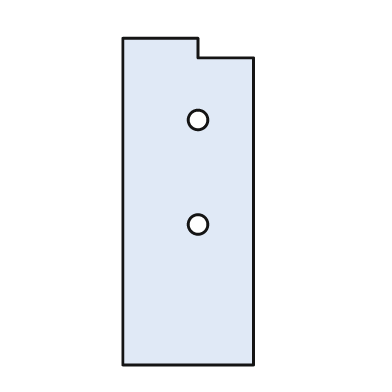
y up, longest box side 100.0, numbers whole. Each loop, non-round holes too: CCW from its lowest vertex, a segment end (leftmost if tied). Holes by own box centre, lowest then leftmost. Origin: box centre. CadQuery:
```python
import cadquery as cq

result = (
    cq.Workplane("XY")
    .moveTo(-20.0, -50.0)
    .lineTo(20.0, -50.0)
    .lineTo(20.0, 44.0)
    .lineTo(3.0, 44.0)
    .lineTo(3.0, 50.0)
    .lineTo(-20.0, 50.0)
    .close()
    .moveTo(3.0, -7.0)
    .circle(3.0)
    .moveTo(3.0, 25.0)
    .circle(3.0)
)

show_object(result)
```